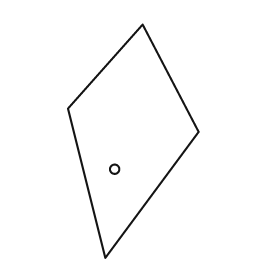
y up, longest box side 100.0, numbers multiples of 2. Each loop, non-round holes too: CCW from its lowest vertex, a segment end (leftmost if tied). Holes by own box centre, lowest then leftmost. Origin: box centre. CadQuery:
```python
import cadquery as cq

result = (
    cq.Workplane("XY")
    .moveTo(-12.0, -50.0)
    .lineTo(28.0, 4.0)
    .lineTo(4.0, 50.0)
    .lineTo(-28.0, 14.0)
    .close()
    .moveTo(-8.0, -12.0)
    .circle(2.0)
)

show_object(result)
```